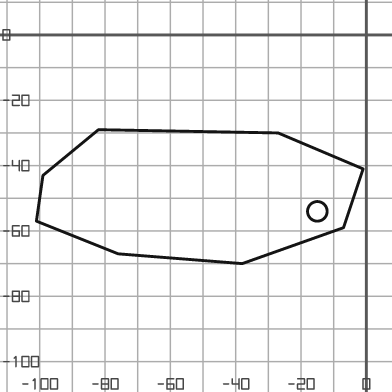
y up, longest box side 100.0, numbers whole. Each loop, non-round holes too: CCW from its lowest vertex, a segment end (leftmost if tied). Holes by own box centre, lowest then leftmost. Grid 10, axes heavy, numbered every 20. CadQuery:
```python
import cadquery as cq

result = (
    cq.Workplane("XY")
    .moveTo(-38.0, -70.0)
    .lineTo(-7.0, -59.0)
    .lineTo(-1.0, -41.0)
    .lineTo(-27.0, -30.0)
    .lineTo(-82.0, -29.0)
    .lineTo(-99.0, -43.0)
    .lineTo(-101.0, -57.0)
    .lineTo(-76.0, -67.0)
    .close()
    .moveTo(-15.0, -54.0)
    .circle(3.0)
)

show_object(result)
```